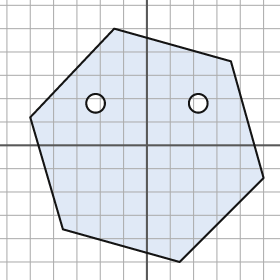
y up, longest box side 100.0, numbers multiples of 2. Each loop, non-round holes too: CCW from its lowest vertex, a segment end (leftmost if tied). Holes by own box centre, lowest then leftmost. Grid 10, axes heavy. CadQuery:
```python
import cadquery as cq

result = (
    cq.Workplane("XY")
    .moveTo(14.0, -50.0)
    .lineTo(50.0, -14.0)
    .lineTo(36.0, 36.0)
    .lineTo(-14.0, 50.0)
    .lineTo(-50.0, 12.0)
    .lineTo(-36.0, -36.0)
    .close()
    .moveTo(-22.0, 18.0)
    .circle(4.0)
    .moveTo(22.0, 18.0)
    .circle(4.0)
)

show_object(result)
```